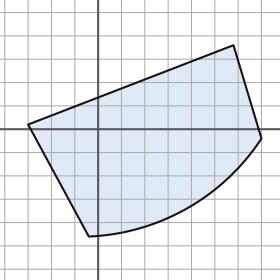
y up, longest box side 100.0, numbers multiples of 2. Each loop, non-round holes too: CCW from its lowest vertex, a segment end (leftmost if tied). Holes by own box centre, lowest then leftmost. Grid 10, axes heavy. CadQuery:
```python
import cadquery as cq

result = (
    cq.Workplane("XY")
    .moveTo(-4.0, -46.0)
    .threePointArc((38.0, -34.0), (70.0, -4.0))
    .lineTo(58.0, 36.0)
    .lineTo(-30.0, 2.0)
    .close()
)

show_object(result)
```